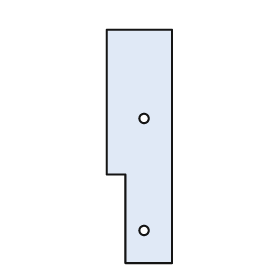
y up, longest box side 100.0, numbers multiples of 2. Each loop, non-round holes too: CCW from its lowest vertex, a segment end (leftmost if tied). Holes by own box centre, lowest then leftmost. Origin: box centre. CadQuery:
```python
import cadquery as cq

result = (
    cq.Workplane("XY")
    .moveTo(-6.0, -50.0)
    .lineTo(14.0, -50.0)
    .lineTo(14.0, 50.0)
    .lineTo(-14.0, 50.0)
    .lineTo(-14.0, -12.0)
    .lineTo(-6.0, -12.0)
    .close()
    .moveTo(2.0, -36.0)
    .circle(2.0)
    .moveTo(2.0, 12.0)
    .circle(2.0)
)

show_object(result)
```